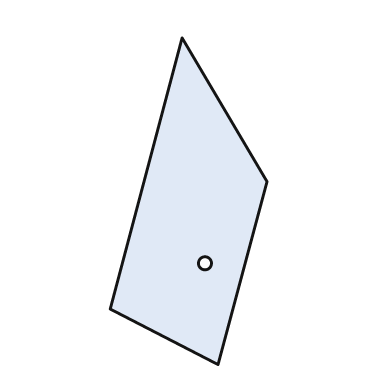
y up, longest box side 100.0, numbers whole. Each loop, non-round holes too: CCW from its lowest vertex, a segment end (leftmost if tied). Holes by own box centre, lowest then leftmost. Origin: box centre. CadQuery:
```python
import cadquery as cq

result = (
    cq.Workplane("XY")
    .moveTo(9.0, -50.0)
    .lineTo(24.0, 6.0)
    .lineTo(-2.0, 50.0)
    .lineTo(-24.0, -33.0)
    .close()
    .moveTo(5.0, -19.0)
    .circle(2.0)
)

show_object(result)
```